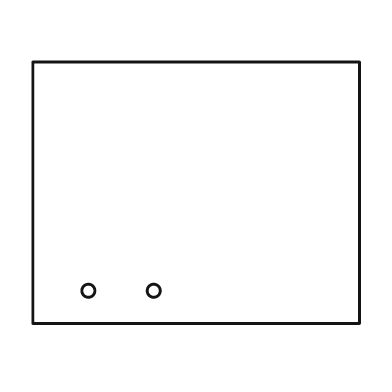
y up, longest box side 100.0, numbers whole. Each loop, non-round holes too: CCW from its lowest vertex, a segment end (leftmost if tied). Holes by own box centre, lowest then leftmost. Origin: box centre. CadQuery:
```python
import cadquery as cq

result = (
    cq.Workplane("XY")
    .moveTo(-50.0, -40.0)
    .lineTo(50.0, -40.0)
    .lineTo(50.0, 40.0)
    .lineTo(-50.0, 40.0)
    .close()
    .moveTo(-33.0, -30.0)
    .circle(2.0)
    .moveTo(-13.0, -30.0)
    .circle(2.0)
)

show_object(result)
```